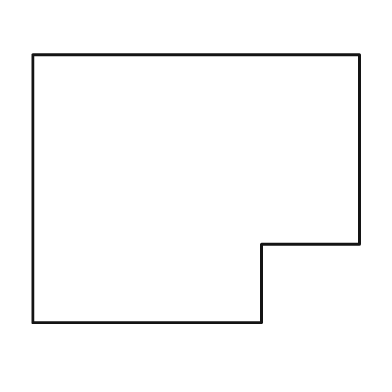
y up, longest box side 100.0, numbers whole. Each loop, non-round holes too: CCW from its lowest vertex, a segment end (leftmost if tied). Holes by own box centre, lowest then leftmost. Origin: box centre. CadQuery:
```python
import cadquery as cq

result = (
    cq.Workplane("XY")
    .moveTo(-50.0, -41.0)
    .lineTo(20.0, -41.0)
    .lineTo(20.0, -17.0)
    .lineTo(50.0, -17.0)
    .lineTo(50.0, 41.0)
    .lineTo(-50.0, 41.0)
    .close()
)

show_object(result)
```